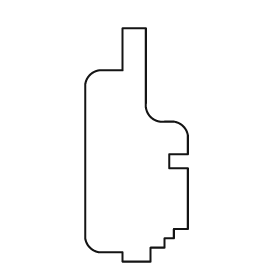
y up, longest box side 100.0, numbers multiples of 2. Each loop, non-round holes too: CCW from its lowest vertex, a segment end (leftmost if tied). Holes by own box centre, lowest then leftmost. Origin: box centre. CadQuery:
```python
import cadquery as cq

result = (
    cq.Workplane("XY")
    .moveTo(-6.0, -50.0)
    .lineTo(6.0, -50.0)
    .lineTo(6.0, -44.0)
    .lineTo(12.0, -44.0)
    .lineTo(12.0, -40.0)
    .lineTo(16.0, -40.0)
    .lineTo(16.0, -36.0)
    .lineTo(22.0, -36.0)
    .lineTo(22.0, -10.0)
    .lineTo(14.0, -10.0)
    .lineTo(14.0, -4.0)
    .lineTo(22.0, -4.0)
    .lineTo(22.0, 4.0)
    .threePointArc((20.0, 8.0), (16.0, 10.0))
    .lineTo(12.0, 10.0)
    .threePointArc((6.0, 12.0), (4.0, 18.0))
    .lineTo(4.0, 50.0)
    .lineTo(-6.0, 50.0)
    .lineTo(-6.0, 32.0)
    .lineTo(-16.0, 32.0)
    .threePointArc((-20.0, 30.0), (-22.0, 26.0))
    .lineTo(-22.0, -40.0)
    .threePointArc((-20.0, -44.0), (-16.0, -46.0))
    .lineTo(-6.0, -46.0)
    .close()
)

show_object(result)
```